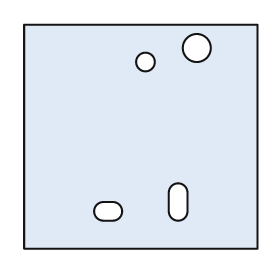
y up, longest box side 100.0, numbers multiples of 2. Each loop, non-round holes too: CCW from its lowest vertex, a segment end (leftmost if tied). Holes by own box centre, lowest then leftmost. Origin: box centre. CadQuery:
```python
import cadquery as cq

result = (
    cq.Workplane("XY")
    .moveTo(-50.0, -48.0)
    .lineTo(50.0, -48.0)
    .lineTo(50.0, 48.0)
    .lineTo(-50.0, 48.0)
    .close()
    .moveTo(-16.0, -36.0)
    .lineTo(-12.0, -36.0)
    .threePointArc((-8.0, -32.0), (-12.0, -28.0))
    .lineTo(-16.0, -28.0)
    .threePointArc((-20.0, -32.0), (-16.0, -36.0))
    .close()
    .moveTo(12.0, -32.0)
    .threePointArc((16.0, -36.0), (20.0, -32.0))
    .lineTo(20.0, -24.0)
    .threePointArc((16.0, -20.0), (12.0, -24.0))
    .close()
    .moveTo(2.0, 32.0)
    .circle(4.0)
    .moveTo(24.0, 38.0)
    .circle(6.0)
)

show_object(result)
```